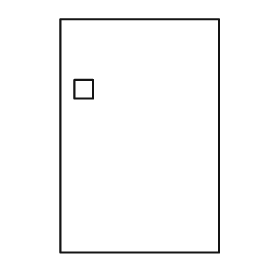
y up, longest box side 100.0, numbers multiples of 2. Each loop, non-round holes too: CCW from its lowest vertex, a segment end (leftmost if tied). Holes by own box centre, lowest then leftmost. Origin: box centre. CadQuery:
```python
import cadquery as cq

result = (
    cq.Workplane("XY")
    .moveTo(-34.0, -50.0)
    .lineTo(34.0, -50.0)
    .lineTo(34.0, 50.0)
    .lineTo(-34.0, 50.0)
    .close()
    .moveTo(-28.0, 16.0)
    .lineTo(-20.0, 16.0)
    .lineTo(-20.0, 24.0)
    .lineTo(-28.0, 24.0)
    .close()
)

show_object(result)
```